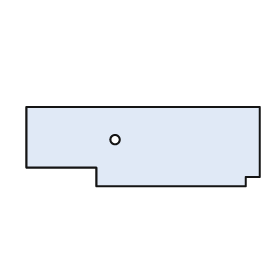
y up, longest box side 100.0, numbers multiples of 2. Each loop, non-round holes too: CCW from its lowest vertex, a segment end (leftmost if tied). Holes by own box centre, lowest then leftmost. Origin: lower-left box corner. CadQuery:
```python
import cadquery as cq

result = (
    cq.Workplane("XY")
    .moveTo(30.0, 0.0)
    .lineTo(94.0, 0.0)
    .lineTo(94.0, 4.0)
    .lineTo(100.0, 4.0)
    .lineTo(100.0, 34.0)
    .lineTo(0.0, 34.0)
    .lineTo(0.0, 8.0)
    .lineTo(30.0, 8.0)
    .close()
    .moveTo(38.0, 20.0)
    .circle(2.0)
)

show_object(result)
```